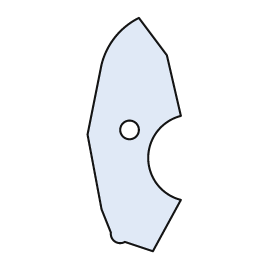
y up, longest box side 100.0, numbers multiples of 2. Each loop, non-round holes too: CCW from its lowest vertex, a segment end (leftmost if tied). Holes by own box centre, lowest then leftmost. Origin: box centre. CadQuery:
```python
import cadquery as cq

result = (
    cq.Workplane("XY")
    .moveTo(8.0, -50.0)
    .lineTo(20.0, -28.0)
    .threePointArc((6.0, -10.0), (20.0, 8.0))
    .lineTo(14.0, 34.0)
    .lineTo(2.0, 50.0)
    .threePointArc((-8.0, 42.0), (-14.0, 30.0))
    .lineTo(-20.0, 0.0)
    .lineTo(-14.0, -32.0)
    .lineTo(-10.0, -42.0)
    .threePointArc((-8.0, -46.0), (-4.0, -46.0))
    .close()
    .moveTo(-2.0, 2.0)
    .circle(4.0)
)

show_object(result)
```